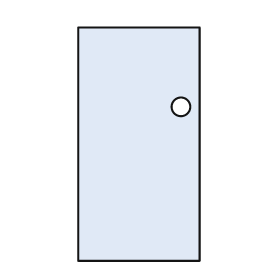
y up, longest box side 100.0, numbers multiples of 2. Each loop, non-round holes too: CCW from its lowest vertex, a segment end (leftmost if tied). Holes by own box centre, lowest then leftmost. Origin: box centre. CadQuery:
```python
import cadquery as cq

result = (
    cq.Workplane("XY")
    .moveTo(-26.0, -50.0)
    .lineTo(26.0, -50.0)
    .lineTo(26.0, 50.0)
    .lineTo(-26.0, 50.0)
    .close()
    .moveTo(18.0, 16.0)
    .circle(4.0)
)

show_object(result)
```